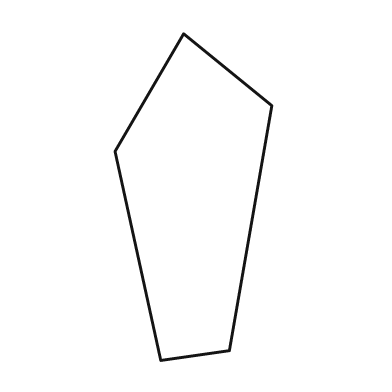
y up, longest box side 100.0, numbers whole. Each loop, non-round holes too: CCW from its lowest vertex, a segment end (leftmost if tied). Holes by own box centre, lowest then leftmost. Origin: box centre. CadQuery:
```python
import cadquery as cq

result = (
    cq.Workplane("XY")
    .moveTo(-10.0, -50.0)
    .lineTo(11.0, -47.0)
    .lineTo(24.0, 28.0)
    .lineTo(-3.0, 50.0)
    .lineTo(-24.0, 14.0)
    .close()
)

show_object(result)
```